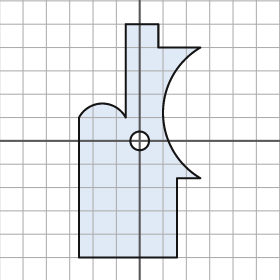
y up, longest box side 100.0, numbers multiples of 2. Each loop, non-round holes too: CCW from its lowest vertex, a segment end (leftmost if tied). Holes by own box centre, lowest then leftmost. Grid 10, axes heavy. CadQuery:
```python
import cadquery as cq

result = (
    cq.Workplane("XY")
    .moveTo(-26.0, -50.0)
    .lineTo(16.0, -50.0)
    .lineTo(16.0, -16.0)
    .lineTo(26.0, -16.0)
    .threePointArc((10.0, 12.0), (26.0, 40.0))
    .lineTo(8.0, 40.0)
    .lineTo(8.0, 50.0)
    .lineTo(-6.0, 50.0)
    .lineTo(-6.0, 10.0)
    .threePointArc((-16.0, 16.0), (-26.0, 10.0))
    .close()
    .moveTo(0.0, 0.0)
    .circle(4.0)
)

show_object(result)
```